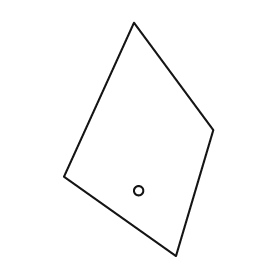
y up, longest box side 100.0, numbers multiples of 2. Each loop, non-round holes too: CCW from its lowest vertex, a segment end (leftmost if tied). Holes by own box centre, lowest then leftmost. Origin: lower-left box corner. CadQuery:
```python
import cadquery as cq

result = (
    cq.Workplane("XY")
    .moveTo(48.0, 0.0)
    .lineTo(64.0, 54.0)
    .lineTo(30.0, 100.0)
    .lineTo(0.0, 34.0)
    .close()
    .moveTo(32.0, 28.0)
    .circle(2.0)
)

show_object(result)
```